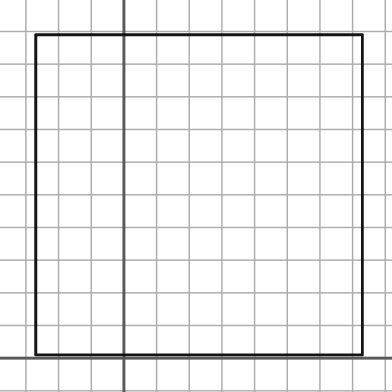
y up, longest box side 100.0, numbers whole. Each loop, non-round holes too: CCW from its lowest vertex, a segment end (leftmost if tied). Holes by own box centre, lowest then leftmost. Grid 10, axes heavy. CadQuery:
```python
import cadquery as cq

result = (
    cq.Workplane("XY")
    .moveTo(-27.0, 1.0)
    .lineTo(73.0, 1.0)
    .lineTo(73.0, 99.0)
    .lineTo(-27.0, 99.0)
    .close()
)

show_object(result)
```